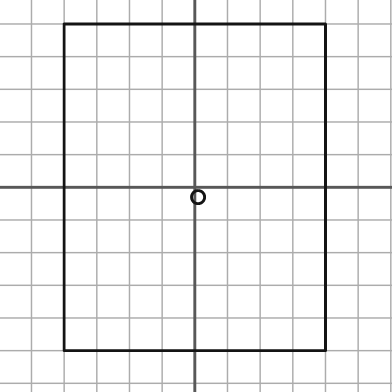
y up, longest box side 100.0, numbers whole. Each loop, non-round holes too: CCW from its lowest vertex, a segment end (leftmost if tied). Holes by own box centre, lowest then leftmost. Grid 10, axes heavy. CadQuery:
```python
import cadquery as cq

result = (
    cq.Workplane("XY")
    .moveTo(-40.0, -50.0)
    .lineTo(40.0, -50.0)
    .lineTo(40.0, 50.0)
    .lineTo(-40.0, 50.0)
    .close()
    .moveTo(1.0, -3.0)
    .circle(2.0)
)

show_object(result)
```